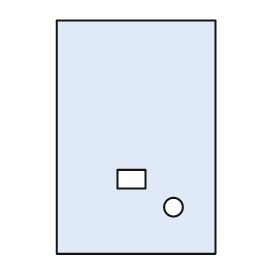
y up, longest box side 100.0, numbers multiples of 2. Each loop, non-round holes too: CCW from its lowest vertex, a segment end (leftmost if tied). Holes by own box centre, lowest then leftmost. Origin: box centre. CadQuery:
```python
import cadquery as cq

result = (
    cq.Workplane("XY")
    .moveTo(-34.0, -50.0)
    .lineTo(34.0, -50.0)
    .lineTo(34.0, 50.0)
    .lineTo(-34.0, 50.0)
    .close()
    .moveTo(16.0, -30.0)
    .circle(4.0)
    .moveTo(-8.0, -22.0)
    .lineTo(4.0, -22.0)
    .lineTo(4.0, -14.0)
    .lineTo(-8.0, -14.0)
    .close()
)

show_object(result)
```